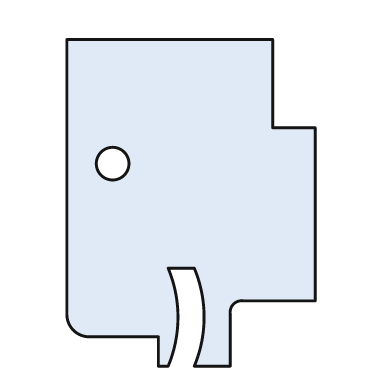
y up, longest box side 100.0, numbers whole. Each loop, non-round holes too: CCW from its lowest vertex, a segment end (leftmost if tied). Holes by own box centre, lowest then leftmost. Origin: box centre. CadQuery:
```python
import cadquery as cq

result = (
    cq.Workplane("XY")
    .moveTo(-10.0, -50.0)
    .lineTo(-7.0, -50.0)
    .threePointArc((-4.0, -35.0), (-7.0, -20.0))
    .lineTo(1.0, -20.0)
    .threePointArc((4.0, -35.0), (1.0, -50.0))
    .lineTo(12.0, -50.0)
    .lineTo(12.0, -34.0)
    .threePointArc((13.0, -31.0), (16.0, -30.0))
    .lineTo(38.0, -30.0)
    .lineTo(38.0, 23.0)
    .lineTo(25.0, 23.0)
    .lineTo(25.0, 50.0)
    .lineTo(-38.0, 50.0)
    .lineTo(-38.0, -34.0)
    .threePointArc((-36.0, -39.0), (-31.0, -41.0))
    .lineTo(-10.0, -41.0)
    .close()
    .moveTo(-24.0, 12.0)
    .circle(5.0)
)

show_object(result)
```